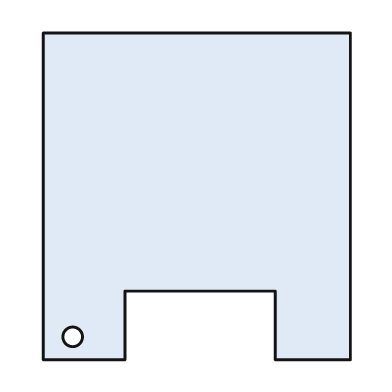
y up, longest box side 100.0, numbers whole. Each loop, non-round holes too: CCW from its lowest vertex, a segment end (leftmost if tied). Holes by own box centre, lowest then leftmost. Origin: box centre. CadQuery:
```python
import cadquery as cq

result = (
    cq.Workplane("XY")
    .moveTo(-47.0, -50.0)
    .lineTo(-22.0, -50.0)
    .lineTo(-22.0, -29.0)
    .lineTo(24.0, -29.0)
    .lineTo(24.0, -50.0)
    .lineTo(47.0, -50.0)
    .lineTo(47.0, 50.0)
    .lineTo(-47.0, 50.0)
    .close()
    .moveTo(-38.0, -43.0)
    .circle(3.0)
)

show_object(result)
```